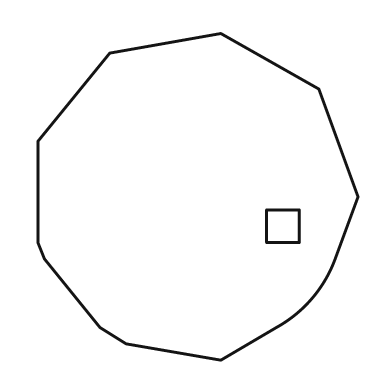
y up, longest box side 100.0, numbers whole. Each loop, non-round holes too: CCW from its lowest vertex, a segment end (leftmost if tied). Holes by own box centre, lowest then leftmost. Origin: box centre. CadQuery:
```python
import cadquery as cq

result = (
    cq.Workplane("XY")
    .moveTo(7.0, -50.0)
    .lineTo(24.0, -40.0)
    .threePointArc((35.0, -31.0), (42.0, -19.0))
    .lineTo(49.0, 0.0)
    .lineTo(37.0, 33.0)
    .lineTo(7.0, 50.0)
    .lineTo(-27.0, 44.0)
    .lineTo(-49.0, 17.0)
    .lineTo(-49.0, -14.0)
    .lineTo(-47.0, -19.0)
    .lineTo(-30.0, -40.0)
    .lineTo(-22.0, -45.0)
    .close()
    .moveTo(21.0, -14.0)
    .lineTo(31.0, -14.0)
    .lineTo(31.0, -4.0)
    .lineTo(21.0, -4.0)
    .close()
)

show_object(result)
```